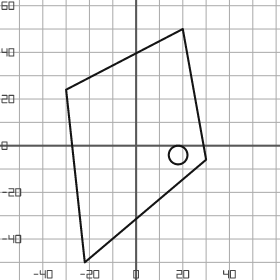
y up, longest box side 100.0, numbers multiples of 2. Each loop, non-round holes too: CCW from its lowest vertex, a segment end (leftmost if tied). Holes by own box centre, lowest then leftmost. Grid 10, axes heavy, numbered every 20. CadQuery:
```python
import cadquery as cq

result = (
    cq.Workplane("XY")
    .moveTo(-22.0, -50.0)
    .lineTo(30.0, -6.0)
    .lineTo(20.0, 50.0)
    .lineTo(-30.0, 24.0)
    .close()
    .moveTo(18.0, -4.0)
    .circle(4.0)
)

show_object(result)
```